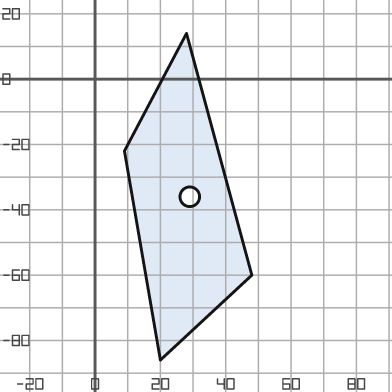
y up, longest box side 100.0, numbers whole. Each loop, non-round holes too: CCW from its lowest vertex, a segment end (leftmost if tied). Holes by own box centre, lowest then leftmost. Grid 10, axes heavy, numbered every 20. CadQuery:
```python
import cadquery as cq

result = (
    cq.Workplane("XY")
    .moveTo(20.0, -86.0)
    .lineTo(48.0, -60.0)
    .lineTo(28.0, 14.0)
    .lineTo(9.0, -22.0)
    .close()
    .moveTo(29.0, -36.0)
    .circle(3.0)
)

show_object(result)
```